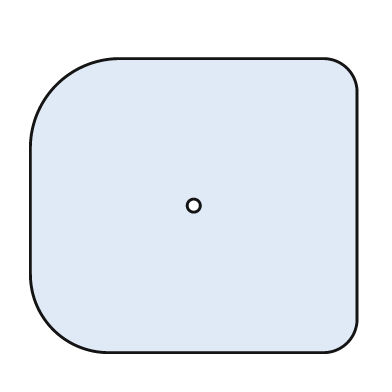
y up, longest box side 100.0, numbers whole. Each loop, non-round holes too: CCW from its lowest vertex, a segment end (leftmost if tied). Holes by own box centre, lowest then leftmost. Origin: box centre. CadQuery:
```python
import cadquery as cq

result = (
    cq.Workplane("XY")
    .moveTo(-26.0, -45.0)
    .lineTo(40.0, -45.0)
    .threePointArc((47.0, -42.0), (50.0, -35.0))
    .lineTo(50.0, 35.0)
    .threePointArc((47.0, 42.0), (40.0, 45.0))
    .lineTo(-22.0, 45.0)
    .threePointArc((-42.0, 37.0), (-50.0, 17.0))
    .lineTo(-50.0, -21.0)
    .threePointArc((-43.0, -38.0), (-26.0, -45.0))
    .close()
    .moveTo(0.0, 0.0)
    .circle(2.0)
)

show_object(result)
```